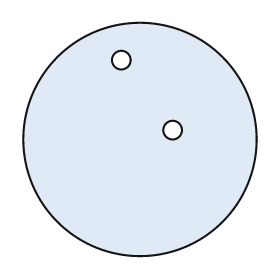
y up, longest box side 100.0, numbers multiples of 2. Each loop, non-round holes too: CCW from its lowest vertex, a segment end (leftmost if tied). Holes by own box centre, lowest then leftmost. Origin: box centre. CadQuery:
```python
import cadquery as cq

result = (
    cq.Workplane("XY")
    .moveTo(0.0, 0.0)
    .circle(50.0)
    .moveTo(14.0, 4.0)
    .circle(4.0)
    .moveTo(-8.0, 34.0)
    .circle(4.0)
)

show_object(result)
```